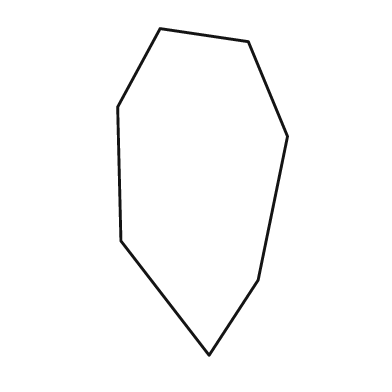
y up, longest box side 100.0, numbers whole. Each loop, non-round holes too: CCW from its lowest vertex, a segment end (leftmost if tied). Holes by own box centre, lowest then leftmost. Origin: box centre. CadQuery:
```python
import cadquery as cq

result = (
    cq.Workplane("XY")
    .moveTo(2.0, -50.0)
    .lineTo(17.0, -27.0)
    .lineTo(26.0, 17.0)
    .lineTo(14.0, 46.0)
    .lineTo(-13.0, 50.0)
    .lineTo(-26.0, 26.0)
    .lineTo(-25.0, -15.0)
    .close()
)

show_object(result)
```